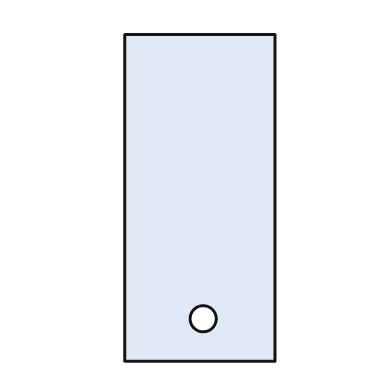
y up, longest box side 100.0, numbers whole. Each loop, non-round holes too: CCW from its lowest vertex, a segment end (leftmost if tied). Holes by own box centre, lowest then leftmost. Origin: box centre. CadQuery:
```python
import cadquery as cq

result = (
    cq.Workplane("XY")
    .moveTo(-23.0, -50.0)
    .lineTo(23.0, -50.0)
    .lineTo(23.0, 50.0)
    .lineTo(-23.0, 50.0)
    .close()
    .moveTo(1.0, -37.0)
    .circle(4.0)
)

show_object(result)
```